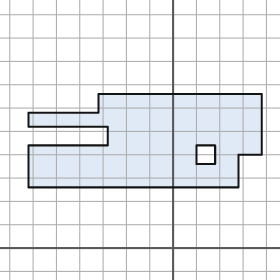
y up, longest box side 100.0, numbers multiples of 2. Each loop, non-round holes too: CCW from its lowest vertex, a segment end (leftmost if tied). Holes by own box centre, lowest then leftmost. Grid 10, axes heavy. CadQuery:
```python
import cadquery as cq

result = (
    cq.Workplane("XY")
    .moveTo(-62.0, 26.0)
    .lineTo(28.0, 26.0)
    .lineTo(28.0, 40.0)
    .lineTo(38.0, 40.0)
    .lineTo(38.0, 66.0)
    .lineTo(-32.0, 66.0)
    .lineTo(-32.0, 58.0)
    .lineTo(-62.0, 58.0)
    .lineTo(-62.0, 52.0)
    .lineTo(-28.0, 52.0)
    .lineTo(-28.0, 44.0)
    .lineTo(-62.0, 44.0)
    .close()
    .moveTo(10.0, 36.0)
    .lineTo(18.0, 36.0)
    .lineTo(18.0, 44.0)
    .lineTo(10.0, 44.0)
    .close()
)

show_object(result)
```